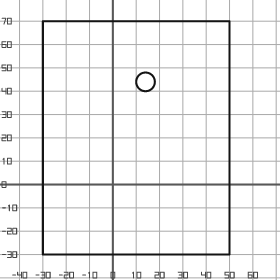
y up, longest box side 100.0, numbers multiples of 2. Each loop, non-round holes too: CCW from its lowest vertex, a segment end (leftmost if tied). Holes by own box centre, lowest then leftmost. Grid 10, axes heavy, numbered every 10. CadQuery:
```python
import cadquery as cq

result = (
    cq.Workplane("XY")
    .moveTo(-30.0, -30.0)
    .lineTo(50.0, -30.0)
    .lineTo(50.0, 70.0)
    .lineTo(-30.0, 70.0)
    .close()
    .moveTo(14.0, 44.0)
    .circle(4.0)
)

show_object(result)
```